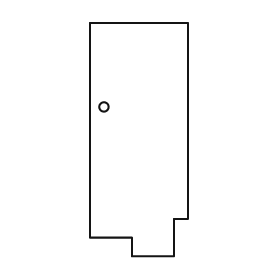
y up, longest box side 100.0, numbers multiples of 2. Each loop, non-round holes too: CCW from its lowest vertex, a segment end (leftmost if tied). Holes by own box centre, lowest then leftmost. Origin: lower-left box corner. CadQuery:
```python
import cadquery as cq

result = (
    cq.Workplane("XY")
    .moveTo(18.0, 0.0)
    .lineTo(36.0, 0.0)
    .lineTo(36.0, 16.0)
    .lineTo(42.0, 16.0)
    .lineTo(42.0, 100.0)
    .lineTo(0.0, 100.0)
    .lineTo(0.0, 8.0)
    .lineTo(18.0, 8.0)
    .close()
    .moveTo(6.0, 64.0)
    .circle(2.0)
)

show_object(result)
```